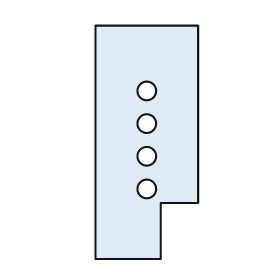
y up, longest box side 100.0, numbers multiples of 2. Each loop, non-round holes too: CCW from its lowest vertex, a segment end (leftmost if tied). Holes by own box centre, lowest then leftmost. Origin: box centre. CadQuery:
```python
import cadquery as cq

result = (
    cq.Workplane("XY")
    .moveTo(-22.0, -50.0)
    .lineTo(6.0, -50.0)
    .lineTo(6.0, -26.0)
    .lineTo(22.0, -26.0)
    .lineTo(22.0, 50.0)
    .lineTo(-22.0, 50.0)
    .close()
    .moveTo(0.0, -20.0)
    .circle(4.0)
    .moveTo(0.0, -6.0)
    .circle(4.0)
    .moveTo(0.0, 8.0)
    .circle(4.0)
    .moveTo(0.0, 22.0)
    .circle(4.0)
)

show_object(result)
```